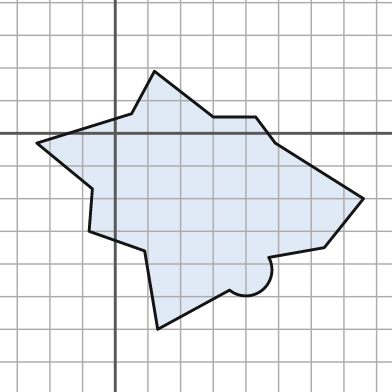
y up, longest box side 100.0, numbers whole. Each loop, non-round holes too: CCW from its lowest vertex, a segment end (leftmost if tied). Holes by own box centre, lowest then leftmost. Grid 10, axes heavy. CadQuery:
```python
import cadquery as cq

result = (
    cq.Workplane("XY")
    .moveTo(13.0, -60.0)
    .lineTo(35.0, -48.0)
    .threePointArc((45.0, -48.0), (47.0, -38.0))
    .lineTo(64.0, -35.0)
    .lineTo(76.0, -20.0)
    .lineTo(49.0, -3.0)
    .lineTo(43.0, 5.0)
    .lineTo(30.0, 5.0)
    .lineTo(12.0, 19.0)
    .lineTo(5.0, 6.0)
    .lineTo(-24.0, -3.0)
    .lineTo(-7.0, -17.0)
    .lineTo(-8.0, -30.0)
    .lineTo(9.0, -36.0)
    .close()
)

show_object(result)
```